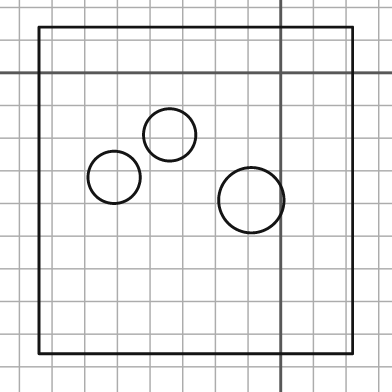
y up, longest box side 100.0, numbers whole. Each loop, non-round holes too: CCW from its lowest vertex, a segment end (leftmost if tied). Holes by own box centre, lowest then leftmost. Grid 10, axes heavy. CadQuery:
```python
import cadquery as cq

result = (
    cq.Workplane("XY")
    .moveTo(-74.0, -86.0)
    .lineTo(22.0, -86.0)
    .lineTo(22.0, 14.0)
    .lineTo(-74.0, 14.0)
    .close()
    .moveTo(-9.0, -39.0)
    .circle(10.0)
    .moveTo(-51.0, -32.0)
    .circle(8.0)
    .moveTo(-34.0, -19.0)
    .circle(8.0)
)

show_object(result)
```